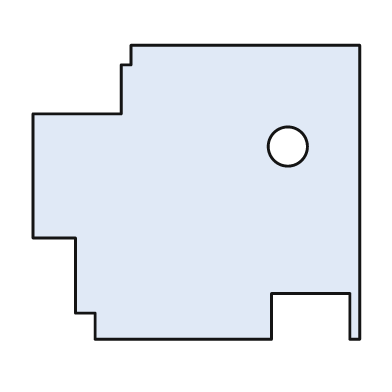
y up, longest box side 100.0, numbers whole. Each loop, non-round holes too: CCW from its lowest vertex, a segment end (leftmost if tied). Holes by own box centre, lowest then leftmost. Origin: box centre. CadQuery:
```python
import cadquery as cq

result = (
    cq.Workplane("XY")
    .moveTo(-31.0, -45.0)
    .lineTo(23.0, -45.0)
    .lineTo(23.0, -31.0)
    .lineTo(47.0, -31.0)
    .lineTo(47.0, -45.0)
    .lineTo(50.0, -45.0)
    .lineTo(50.0, 45.0)
    .lineTo(-20.0, 45.0)
    .lineTo(-20.0, 39.0)
    .lineTo(-23.0, 39.0)
    .lineTo(-23.0, 24.0)
    .lineTo(-50.0, 24.0)
    .lineTo(-50.0, -14.0)
    .lineTo(-37.0, -14.0)
    .lineTo(-37.0, -37.0)
    .lineTo(-31.0, -37.0)
    .close()
    .moveTo(28.0, 14.0)
    .circle(6.0)
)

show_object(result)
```